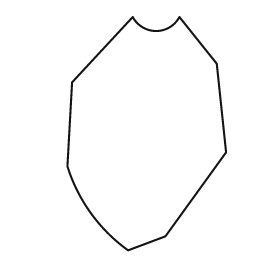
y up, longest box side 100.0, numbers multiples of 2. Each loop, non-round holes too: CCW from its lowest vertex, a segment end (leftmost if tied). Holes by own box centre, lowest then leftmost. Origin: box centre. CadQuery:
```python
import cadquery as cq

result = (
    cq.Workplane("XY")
    .moveTo(-8.0, -50.0)
    .lineTo(8.0, -44.0)
    .lineTo(34.0, -8.0)
    .lineTo(30.0, 30.0)
    .lineTo(14.0, 50.0)
    .threePointArc((4.0, 44.0), (-6.0, 50.0))
    .lineTo(-32.0, 22.0)
    .lineTo(-34.0, -14.0)
    .threePointArc((-24.0, -34.0), (-8.0, -50.0))
    .close()
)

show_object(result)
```